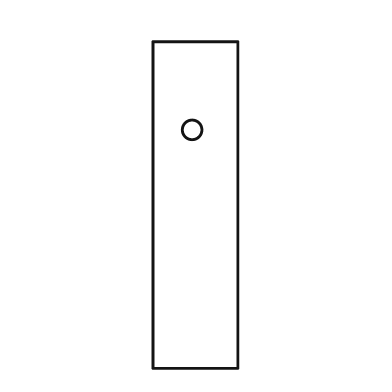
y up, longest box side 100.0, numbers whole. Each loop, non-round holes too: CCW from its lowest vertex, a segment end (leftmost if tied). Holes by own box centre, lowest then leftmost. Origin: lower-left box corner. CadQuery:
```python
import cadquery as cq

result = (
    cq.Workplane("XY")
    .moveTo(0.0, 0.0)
    .lineTo(26.0, 0.0)
    .lineTo(26.0, 100.0)
    .lineTo(0.0, 100.0)
    .close()
    .moveTo(12.0, 73.0)
    .circle(3.0)
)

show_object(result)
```